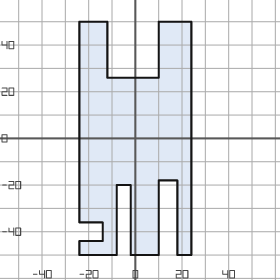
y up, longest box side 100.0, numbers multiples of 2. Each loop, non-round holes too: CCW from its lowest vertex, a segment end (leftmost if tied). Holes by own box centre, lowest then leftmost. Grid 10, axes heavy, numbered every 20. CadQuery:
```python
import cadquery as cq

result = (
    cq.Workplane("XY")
    .moveTo(-24.0, -50.0)
    .lineTo(-8.0, -50.0)
    .lineTo(-8.0, -20.0)
    .lineTo(-2.0, -20.0)
    .lineTo(-2.0, -50.0)
    .lineTo(10.0, -50.0)
    .lineTo(10.0, -18.0)
    .lineTo(18.0, -18.0)
    .lineTo(18.0, -50.0)
    .lineTo(24.0, -50.0)
    .lineTo(24.0, 50.0)
    .lineTo(10.0, 50.0)
    .lineTo(10.0, 26.0)
    .lineTo(-12.0, 26.0)
    .lineTo(-12.0, 50.0)
    .lineTo(-24.0, 50.0)
    .lineTo(-24.0, -36.0)
    .lineTo(-14.0, -36.0)
    .lineTo(-14.0, -44.0)
    .lineTo(-24.0, -44.0)
    .close()
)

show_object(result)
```